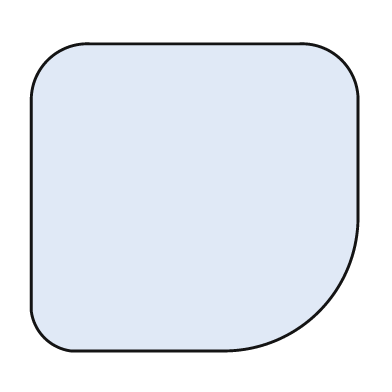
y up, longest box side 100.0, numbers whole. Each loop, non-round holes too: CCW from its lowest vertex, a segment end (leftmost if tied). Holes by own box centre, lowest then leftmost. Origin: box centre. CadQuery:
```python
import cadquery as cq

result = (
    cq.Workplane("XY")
    .moveTo(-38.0, -47.0)
    .lineTo(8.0, -47.0)
    .threePointArc((38.0, -35.0), (50.0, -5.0))
    .lineTo(50.0, 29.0)
    .threePointArc((45.0, 42.0), (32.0, 47.0))
    .lineTo(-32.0, 47.0)
    .threePointArc((-45.0, 42.0), (-50.0, 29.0))
    .lineTo(-50.0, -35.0)
    .threePointArc((-46.0, -43.0), (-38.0, -47.0))
    .close()
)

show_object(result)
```